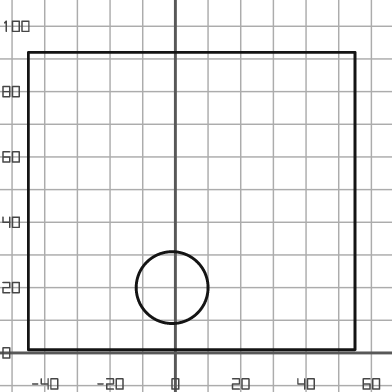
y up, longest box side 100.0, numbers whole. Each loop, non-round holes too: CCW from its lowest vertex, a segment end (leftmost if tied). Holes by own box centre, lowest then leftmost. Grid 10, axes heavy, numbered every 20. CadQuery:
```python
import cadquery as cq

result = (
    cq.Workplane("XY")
    .moveTo(-45.0, 1.0)
    .lineTo(55.0, 1.0)
    .lineTo(55.0, 92.0)
    .lineTo(-45.0, 92.0)
    .close()
    .moveTo(-1.0, 20.0)
    .circle(11.0)
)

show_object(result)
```